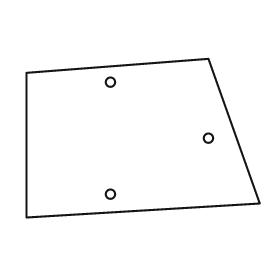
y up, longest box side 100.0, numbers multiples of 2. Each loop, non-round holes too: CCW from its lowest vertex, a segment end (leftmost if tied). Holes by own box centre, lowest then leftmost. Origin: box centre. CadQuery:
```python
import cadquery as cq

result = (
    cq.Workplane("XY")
    .moveTo(-50.0, -34.0)
    .lineTo(50.0, -28.0)
    .lineTo(28.0, 34.0)
    .lineTo(-50.0, 28.0)
    .close()
    .moveTo(-14.0, -24.0)
    .circle(2.0)
    .moveTo(28.0, 0.0)
    .circle(2.0)
    .moveTo(-14.0, 24.0)
    .circle(2.0)
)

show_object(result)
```